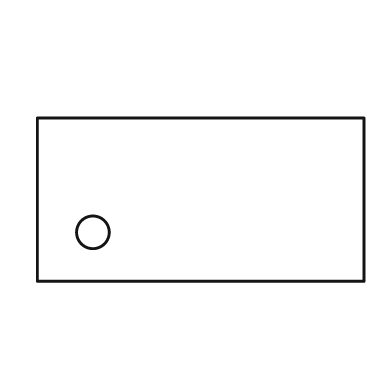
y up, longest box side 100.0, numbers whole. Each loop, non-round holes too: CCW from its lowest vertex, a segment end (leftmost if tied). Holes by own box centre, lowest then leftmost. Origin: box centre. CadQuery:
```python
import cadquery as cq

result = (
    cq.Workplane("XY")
    .moveTo(-50.0, -25.0)
    .lineTo(50.0, -25.0)
    .lineTo(50.0, 25.0)
    .lineTo(-50.0, 25.0)
    .close()
    .moveTo(-33.0, -10.0)
    .circle(5.0)
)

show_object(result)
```